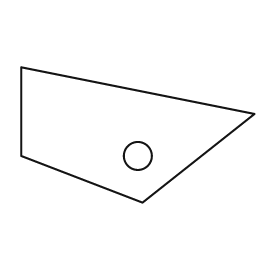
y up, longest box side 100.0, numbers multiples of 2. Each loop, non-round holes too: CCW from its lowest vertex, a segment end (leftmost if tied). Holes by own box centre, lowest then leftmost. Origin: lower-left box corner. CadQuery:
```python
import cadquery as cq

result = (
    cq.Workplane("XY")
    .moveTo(52.0, 0.0)
    .lineTo(100.0, 38.0)
    .lineTo(0.0, 58.0)
    .lineTo(0.0, 20.0)
    .close()
    .moveTo(50.0, 20.0)
    .circle(6.0)
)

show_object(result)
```